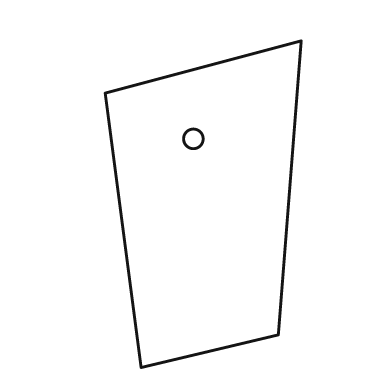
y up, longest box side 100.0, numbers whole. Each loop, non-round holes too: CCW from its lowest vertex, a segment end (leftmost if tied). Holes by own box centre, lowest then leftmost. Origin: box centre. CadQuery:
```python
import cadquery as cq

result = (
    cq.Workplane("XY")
    .moveTo(-19.0, -50.0)
    .lineTo(23.0, -40.0)
    .lineTo(30.0, 50.0)
    .lineTo(-30.0, 34.0)
    .close()
    .moveTo(-3.0, 20.0)
    .circle(3.0)
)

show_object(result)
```